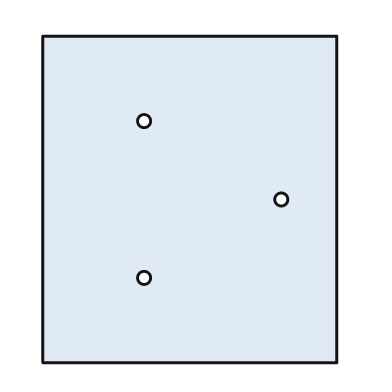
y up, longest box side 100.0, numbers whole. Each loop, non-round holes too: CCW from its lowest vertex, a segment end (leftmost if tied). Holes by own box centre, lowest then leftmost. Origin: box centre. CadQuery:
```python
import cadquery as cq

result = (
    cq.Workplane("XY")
    .moveTo(-45.0, -50.0)
    .lineTo(45.0, -50.0)
    .lineTo(45.0, 50.0)
    .lineTo(-45.0, 50.0)
    .close()
    .moveTo(-14.0, -24.0)
    .circle(2.0)
    .moveTo(28.0, 0.0)
    .circle(2.0)
    .moveTo(-14.0, 24.0)
    .circle(2.0)
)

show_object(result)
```